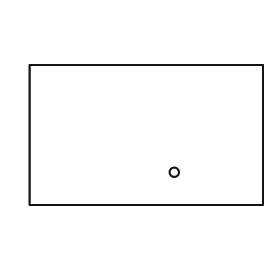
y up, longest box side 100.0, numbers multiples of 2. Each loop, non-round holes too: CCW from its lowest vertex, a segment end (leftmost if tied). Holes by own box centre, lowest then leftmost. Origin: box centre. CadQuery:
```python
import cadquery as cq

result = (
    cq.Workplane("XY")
    .moveTo(-50.0, -30.0)
    .lineTo(50.0, -30.0)
    .lineTo(50.0, 30.0)
    .lineTo(-50.0, 30.0)
    .close()
    .moveTo(12.0, -16.0)
    .circle(2.0)
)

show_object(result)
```